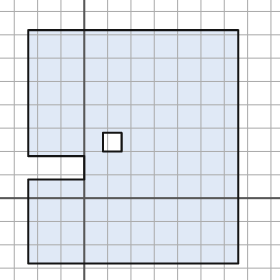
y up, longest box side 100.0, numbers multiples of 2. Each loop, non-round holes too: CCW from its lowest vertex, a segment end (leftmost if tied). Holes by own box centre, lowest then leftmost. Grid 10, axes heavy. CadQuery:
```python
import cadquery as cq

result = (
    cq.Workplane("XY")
    .moveTo(-24.0, -28.0)
    .lineTo(66.0, -28.0)
    .lineTo(66.0, 72.0)
    .lineTo(-24.0, 72.0)
    .lineTo(-24.0, 18.0)
    .lineTo(0.0, 18.0)
    .lineTo(0.0, 8.0)
    .lineTo(-24.0, 8.0)
    .close()
    .moveTo(8.0, 20.0)
    .lineTo(16.0, 20.0)
    .lineTo(16.0, 28.0)
    .lineTo(8.0, 28.0)
    .close()
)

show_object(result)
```